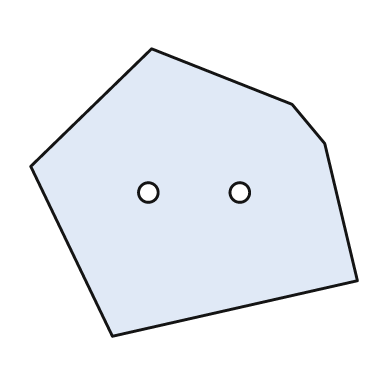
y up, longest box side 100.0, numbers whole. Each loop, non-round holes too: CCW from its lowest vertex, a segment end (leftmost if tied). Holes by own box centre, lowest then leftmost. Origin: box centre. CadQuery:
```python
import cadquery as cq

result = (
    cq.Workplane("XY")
    .moveTo(-25.0, -44.0)
    .lineTo(50.0, -27.0)
    .lineTo(40.0, 15.0)
    .lineTo(30.0, 27.0)
    .lineTo(-13.0, 44.0)
    .lineTo(-50.0, 8.0)
    .close()
    .moveTo(-14.0, 0.0)
    .circle(3.0)
    .moveTo(14.0, 0.0)
    .circle(3.0)
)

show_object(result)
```